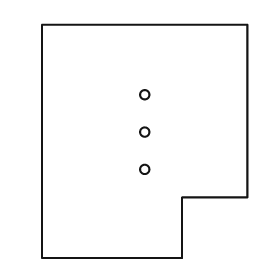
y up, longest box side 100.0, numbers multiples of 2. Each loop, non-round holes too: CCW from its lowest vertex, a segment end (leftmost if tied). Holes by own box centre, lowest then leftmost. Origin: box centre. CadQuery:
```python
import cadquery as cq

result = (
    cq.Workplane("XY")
    .moveTo(-44.0, -50.0)
    .lineTo(16.0, -50.0)
    .lineTo(16.0, -24.0)
    .lineTo(44.0, -24.0)
    .lineTo(44.0, 50.0)
    .lineTo(-44.0, 50.0)
    .close()
    .moveTo(0.0, -12.0)
    .circle(2.0)
    .moveTo(0.0, 4.0)
    .circle(2.0)
    .moveTo(0.0, 20.0)
    .circle(2.0)
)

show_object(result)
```